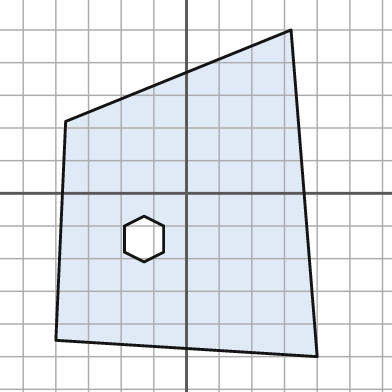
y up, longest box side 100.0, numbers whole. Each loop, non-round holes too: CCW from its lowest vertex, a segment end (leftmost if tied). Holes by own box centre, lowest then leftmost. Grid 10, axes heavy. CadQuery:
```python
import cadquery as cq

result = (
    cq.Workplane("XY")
    .moveTo(40.0, -50.0)
    .lineTo(32.0, 50.0)
    .lineTo(-37.0, 22.0)
    .lineTo(-40.0, -45.0)
    .close()
    .moveTo(-13.0, -21.0)
    .lineTo(-7.0, -18.0)
    .lineTo(-7.0, -10.0)
    .lineTo(-13.0, -7.0)
    .lineTo(-19.0, -10.0)
    .lineTo(-19.0, -18.0)
    .close()
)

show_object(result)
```